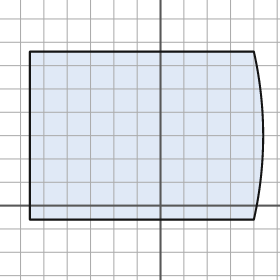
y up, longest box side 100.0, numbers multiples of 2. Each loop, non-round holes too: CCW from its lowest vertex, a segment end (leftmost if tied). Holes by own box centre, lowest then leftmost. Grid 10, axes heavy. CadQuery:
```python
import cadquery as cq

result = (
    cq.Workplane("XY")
    .moveTo(-56.0, -6.0)
    .lineTo(40.0, -6.0)
    .threePointArc((44.0, 30.0), (40.0, 66.0))
    .lineTo(-56.0, 66.0)
    .close()
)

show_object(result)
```